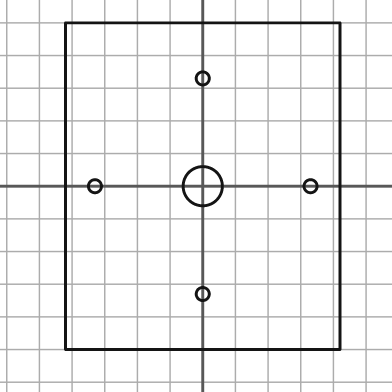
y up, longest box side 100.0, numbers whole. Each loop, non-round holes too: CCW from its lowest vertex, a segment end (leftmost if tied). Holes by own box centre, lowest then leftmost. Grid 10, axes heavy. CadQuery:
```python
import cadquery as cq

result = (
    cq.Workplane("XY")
    .moveTo(-42.0, -50.0)
    .lineTo(42.0, -50.0)
    .lineTo(42.0, 50.0)
    .lineTo(-42.0, 50.0)
    .close()
    .moveTo(0.0, -33.0)
    .circle(2.0)
    .moveTo(-33.0, 0.0)
    .circle(2.0)
    .moveTo(0.0, 0.0)
    .circle(6.0)
    .moveTo(33.0, 0.0)
    .circle(2.0)
    .moveTo(0.0, 33.0)
    .circle(2.0)
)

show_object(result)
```